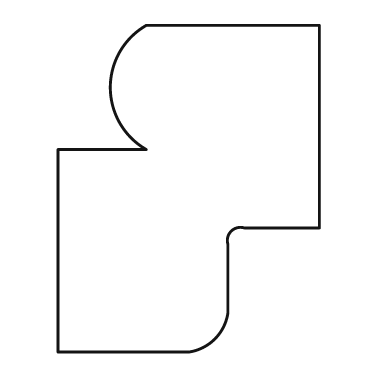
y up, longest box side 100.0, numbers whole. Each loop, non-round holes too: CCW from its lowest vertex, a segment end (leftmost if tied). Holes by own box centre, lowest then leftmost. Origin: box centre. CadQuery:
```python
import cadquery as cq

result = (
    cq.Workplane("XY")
    .moveTo(-40.0, -50.0)
    .lineTo(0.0, -50.0)
    .threePointArc((8.0, -46.0), (12.0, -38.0))
    .lineTo(12.0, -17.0)
    .threePointArc((13.0, -13.0), (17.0, -12.0))
    .lineTo(40.0, -12.0)
    .lineTo(40.0, 50.0)
    .lineTo(-13.0, 50.0)
    .threePointArc((-24.0, 31.0), (-13.0, 12.0))
    .lineTo(-40.0, 12.0)
    .close()
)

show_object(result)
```